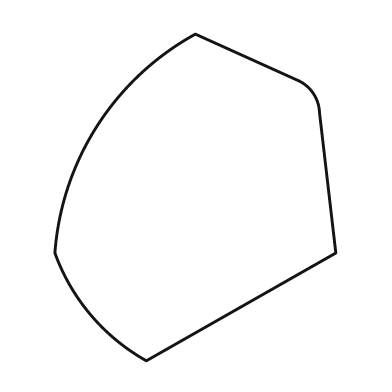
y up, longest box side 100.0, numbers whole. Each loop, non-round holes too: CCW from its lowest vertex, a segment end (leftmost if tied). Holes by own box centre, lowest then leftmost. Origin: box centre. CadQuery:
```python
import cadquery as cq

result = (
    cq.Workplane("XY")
    .moveTo(-15.0, -50.0)
    .lineTo(43.0, -17.0)
    .lineTo(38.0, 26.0)
    .threePointArc((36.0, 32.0), (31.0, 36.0))
    .lineTo(0.0, 50.0)
    .threePointArc((-30.0, 22.0), (-43.0, -17.0))
    .threePointArc((-32.0, -36.0), (-15.0, -50.0))
    .close()
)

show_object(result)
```